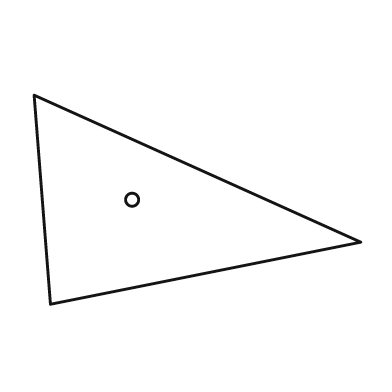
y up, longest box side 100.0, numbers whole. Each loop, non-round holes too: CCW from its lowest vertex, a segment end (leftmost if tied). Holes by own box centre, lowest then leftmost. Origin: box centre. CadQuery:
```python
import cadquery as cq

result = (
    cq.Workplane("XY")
    .moveTo(-45.0, -32.0)
    .lineTo(50.0, -13.0)
    .lineTo(-50.0, 32.0)
    .close()
    .moveTo(-20.0, 0.0)
    .circle(2.0)
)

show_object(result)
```